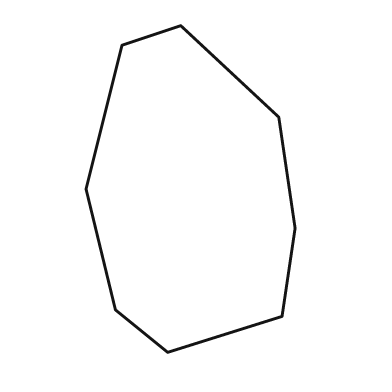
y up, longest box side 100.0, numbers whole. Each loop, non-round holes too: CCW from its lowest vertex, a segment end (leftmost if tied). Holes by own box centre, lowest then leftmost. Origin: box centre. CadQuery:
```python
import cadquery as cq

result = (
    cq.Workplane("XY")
    .moveTo(-7.0, -50.0)
    .lineTo(28.0, -39.0)
    .lineTo(32.0, -12.0)
    .lineTo(27.0, 22.0)
    .lineTo(-3.0, 50.0)
    .lineTo(-21.0, 44.0)
    .lineTo(-32.0, 0.0)
    .lineTo(-23.0, -37.0)
    .close()
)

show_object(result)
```